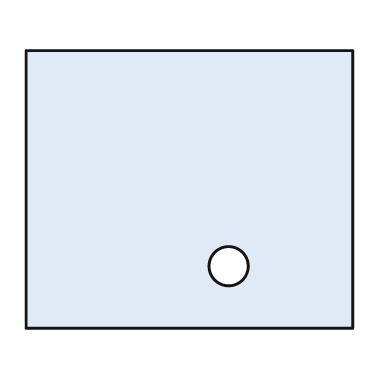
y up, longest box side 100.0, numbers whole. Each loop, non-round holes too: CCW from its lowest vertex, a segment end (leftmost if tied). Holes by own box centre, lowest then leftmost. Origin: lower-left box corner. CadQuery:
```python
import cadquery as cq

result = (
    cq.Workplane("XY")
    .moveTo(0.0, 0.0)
    .lineTo(100.0, 0.0)
    .lineTo(100.0, 85.0)
    .lineTo(0.0, 85.0)
    .close()
    .moveTo(62.0, 19.0)
    .circle(6.0)
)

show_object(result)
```